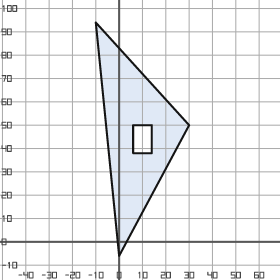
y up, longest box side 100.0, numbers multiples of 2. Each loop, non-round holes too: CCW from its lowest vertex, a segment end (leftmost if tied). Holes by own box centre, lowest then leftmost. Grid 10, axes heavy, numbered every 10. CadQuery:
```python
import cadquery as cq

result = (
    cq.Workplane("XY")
    .moveTo(0.0, -6.0)
    .lineTo(30.0, 50.0)
    .lineTo(-10.0, 94.0)
    .close()
    .moveTo(6.0, 38.0)
    .lineTo(14.0, 38.0)
    .lineTo(14.0, 50.0)
    .lineTo(6.0, 50.0)
    .close()
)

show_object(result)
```